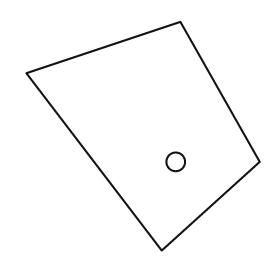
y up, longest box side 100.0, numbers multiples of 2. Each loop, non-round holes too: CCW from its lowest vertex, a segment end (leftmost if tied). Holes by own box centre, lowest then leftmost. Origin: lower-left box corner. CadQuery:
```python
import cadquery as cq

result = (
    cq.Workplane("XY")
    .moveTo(58.0, 0.0)
    .lineTo(100.0, 38.0)
    .lineTo(66.0, 98.0)
    .lineTo(0.0, 76.0)
    .close()
    .moveTo(64.0, 38.0)
    .circle(4.0)
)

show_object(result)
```